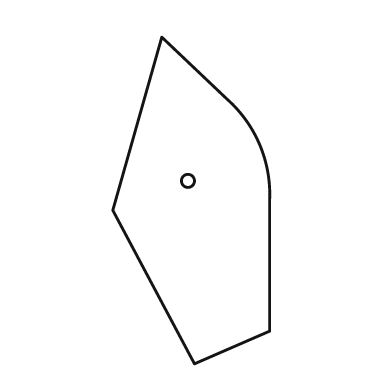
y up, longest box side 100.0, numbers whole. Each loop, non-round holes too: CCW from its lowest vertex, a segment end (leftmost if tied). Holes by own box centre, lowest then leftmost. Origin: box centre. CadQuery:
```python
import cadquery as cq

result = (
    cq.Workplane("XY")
    .moveTo(1.0, -50.0)
    .lineTo(24.0, -40.0)
    .lineTo(24.0, 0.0)
    .threePointArc((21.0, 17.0), (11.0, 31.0))
    .lineTo(-9.0, 50.0)
    .lineTo(-24.0, -3.0)
    .close()
    .moveTo(-1.0, 6.0)
    .circle(2.0)
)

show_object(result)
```